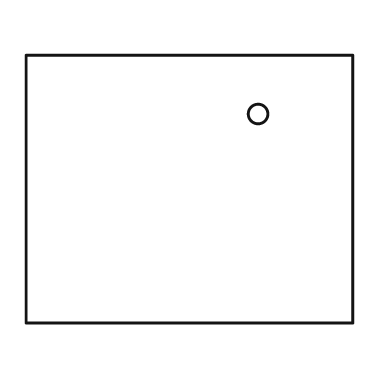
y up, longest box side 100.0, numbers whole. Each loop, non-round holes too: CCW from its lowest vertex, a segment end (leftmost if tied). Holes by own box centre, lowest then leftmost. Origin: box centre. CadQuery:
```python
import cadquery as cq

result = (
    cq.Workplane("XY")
    .moveTo(-50.0, -41.0)
    .lineTo(50.0, -41.0)
    .lineTo(50.0, 41.0)
    .lineTo(-50.0, 41.0)
    .close()
    .moveTo(21.0, 23.0)
    .circle(3.0)
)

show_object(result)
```